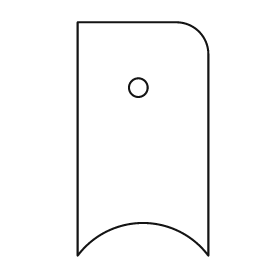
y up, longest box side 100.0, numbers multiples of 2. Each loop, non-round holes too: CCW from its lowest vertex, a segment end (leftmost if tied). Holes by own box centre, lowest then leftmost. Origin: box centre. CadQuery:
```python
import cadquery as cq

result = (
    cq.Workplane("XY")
    .moveTo(-28.0, -50.0)
    .threePointArc((0.0, -36.0), (28.0, -50.0))
    .lineTo(28.0, 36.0)
    .threePointArc((24.0, 46.0), (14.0, 50.0))
    .lineTo(-28.0, 50.0)
    .close()
    .moveTo(-2.0, 22.0)
    .circle(4.0)
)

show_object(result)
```